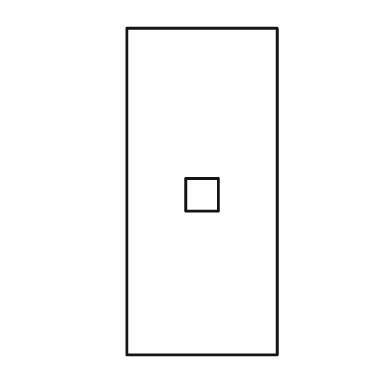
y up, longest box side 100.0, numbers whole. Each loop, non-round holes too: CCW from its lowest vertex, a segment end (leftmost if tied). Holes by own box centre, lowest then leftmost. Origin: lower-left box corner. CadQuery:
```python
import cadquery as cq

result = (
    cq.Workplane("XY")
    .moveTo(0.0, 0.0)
    .lineTo(46.0, 0.0)
    .lineTo(46.0, 100.0)
    .lineTo(0.0, 100.0)
    .close()
    .moveTo(18.0, 44.0)
    .lineTo(28.0, 44.0)
    .lineTo(28.0, 54.0)
    .lineTo(18.0, 54.0)
    .close()
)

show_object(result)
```